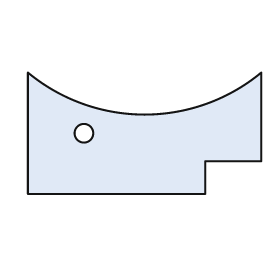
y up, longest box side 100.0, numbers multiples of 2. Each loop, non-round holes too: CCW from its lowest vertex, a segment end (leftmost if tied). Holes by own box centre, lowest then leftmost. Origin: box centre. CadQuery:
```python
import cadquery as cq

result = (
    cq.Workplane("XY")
    .moveTo(-50.0, -26.0)
    .lineTo(26.0, -26.0)
    .lineTo(26.0, -12.0)
    .lineTo(50.0, -12.0)
    .lineTo(50.0, 26.0)
    .threePointArc((0.0, 8.0), (-50.0, 26.0))
    .close()
    .moveTo(-26.0, 0.0)
    .circle(4.0)
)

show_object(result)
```